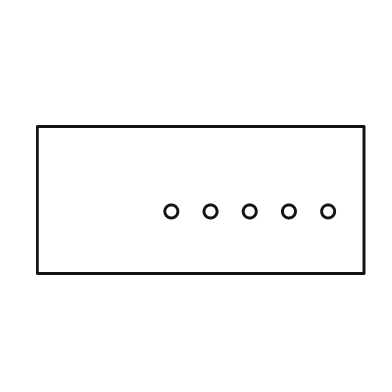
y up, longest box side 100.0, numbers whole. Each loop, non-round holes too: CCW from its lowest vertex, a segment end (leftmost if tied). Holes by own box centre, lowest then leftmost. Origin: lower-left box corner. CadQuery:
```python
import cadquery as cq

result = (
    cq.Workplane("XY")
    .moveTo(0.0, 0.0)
    .lineTo(100.0, 0.0)
    .lineTo(100.0, 45.0)
    .lineTo(0.0, 45.0)
    .close()
    .moveTo(41.0, 19.0)
    .circle(2.0)
    .moveTo(53.0, 19.0)
    .circle(2.0)
    .moveTo(65.0, 19.0)
    .circle(2.0)
    .moveTo(77.0, 19.0)
    .circle(2.0)
    .moveTo(89.0, 19.0)
    .circle(2.0)
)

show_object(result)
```